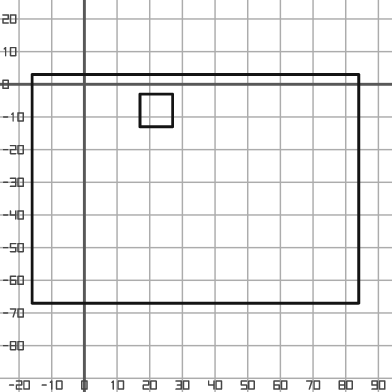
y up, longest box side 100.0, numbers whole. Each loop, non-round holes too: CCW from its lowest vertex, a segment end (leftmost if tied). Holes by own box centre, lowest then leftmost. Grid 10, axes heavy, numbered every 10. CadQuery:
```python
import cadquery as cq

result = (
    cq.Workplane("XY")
    .moveTo(-16.0, -67.0)
    .lineTo(84.0, -67.0)
    .lineTo(84.0, 3.0)
    .lineTo(-16.0, 3.0)
    .close()
    .moveTo(17.0, -13.0)
    .lineTo(27.0, -13.0)
    .lineTo(27.0, -3.0)
    .lineTo(17.0, -3.0)
    .close()
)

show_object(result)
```